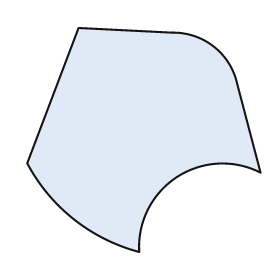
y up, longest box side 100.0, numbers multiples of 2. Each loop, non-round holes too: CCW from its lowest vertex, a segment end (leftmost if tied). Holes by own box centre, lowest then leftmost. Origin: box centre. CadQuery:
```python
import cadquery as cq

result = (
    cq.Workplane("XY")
    .moveTo(-2.0, -48.0)
    .threePointArc((14.0, -16.0), (50.0, -14.0))
    .lineTo(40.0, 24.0)
    .threePointArc((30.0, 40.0), (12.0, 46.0))
    .lineTo(-28.0, 48.0)
    .lineTo(-50.0, -10.0)
    .threePointArc((-30.0, -34.0), (-2.0, -48.0))
    .close()
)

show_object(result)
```